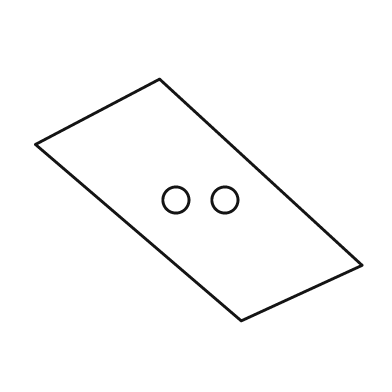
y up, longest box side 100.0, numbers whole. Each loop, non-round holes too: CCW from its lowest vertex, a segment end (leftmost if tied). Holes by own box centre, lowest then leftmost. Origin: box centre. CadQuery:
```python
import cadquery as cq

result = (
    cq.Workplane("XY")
    .moveTo(13.0, -37.0)
    .lineTo(50.0, -20.0)
    .lineTo(-12.0, 37.0)
    .lineTo(-50.0, 17.0)
    .close()
    .moveTo(-7.0, 0.0)
    .circle(4.0)
    .moveTo(8.0, 0.0)
    .circle(4.0)
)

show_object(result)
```